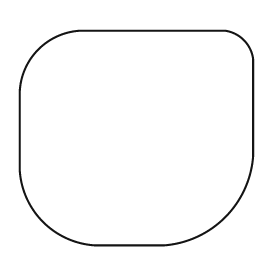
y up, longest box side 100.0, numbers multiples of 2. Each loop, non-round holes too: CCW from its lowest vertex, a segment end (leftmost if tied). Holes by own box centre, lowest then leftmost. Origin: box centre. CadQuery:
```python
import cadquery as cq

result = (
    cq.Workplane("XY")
    .moveTo(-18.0, -46.0)
    .lineTo(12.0, -46.0)
    .threePointArc((38.0, -34.0), (50.0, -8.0))
    .lineTo(50.0, 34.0)
    .threePointArc((46.0, 42.0), (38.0, 46.0))
    .lineTo(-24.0, 46.0)
    .threePointArc((-42.0, 38.0), (-50.0, 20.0))
    .lineTo(-50.0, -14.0)
    .threePointArc((-40.0, -36.0), (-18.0, -46.0))
    .close()
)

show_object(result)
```